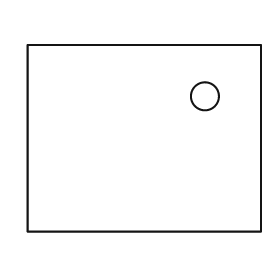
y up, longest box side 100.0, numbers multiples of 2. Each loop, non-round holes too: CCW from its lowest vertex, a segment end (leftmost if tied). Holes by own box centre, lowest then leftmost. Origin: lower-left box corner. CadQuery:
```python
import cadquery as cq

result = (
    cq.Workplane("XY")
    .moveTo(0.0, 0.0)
    .lineTo(100.0, 0.0)
    .lineTo(100.0, 80.0)
    .lineTo(0.0, 80.0)
    .close()
    .moveTo(76.0, 58.0)
    .circle(6.0)
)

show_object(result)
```